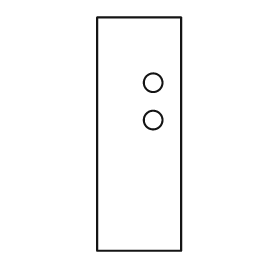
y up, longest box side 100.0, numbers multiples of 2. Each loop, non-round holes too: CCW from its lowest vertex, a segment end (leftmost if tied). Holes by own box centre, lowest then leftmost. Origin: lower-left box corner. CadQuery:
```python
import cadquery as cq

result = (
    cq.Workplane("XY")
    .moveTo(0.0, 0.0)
    .lineTo(36.0, 0.0)
    .lineTo(36.0, 100.0)
    .lineTo(0.0, 100.0)
    .close()
    .moveTo(24.0, 56.0)
    .circle(4.0)
    .moveTo(24.0, 72.0)
    .circle(4.0)
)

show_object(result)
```